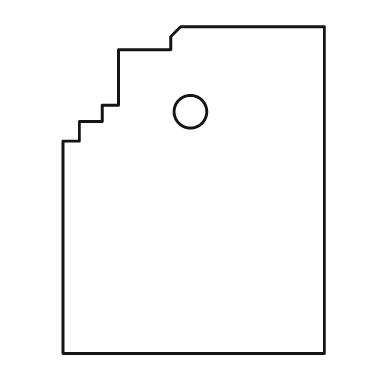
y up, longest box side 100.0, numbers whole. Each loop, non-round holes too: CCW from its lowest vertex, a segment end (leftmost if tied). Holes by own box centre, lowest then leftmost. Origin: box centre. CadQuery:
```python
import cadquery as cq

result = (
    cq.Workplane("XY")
    .moveTo(-40.0, -50.0)
    .lineTo(40.0, -50.0)
    .lineTo(40.0, 50.0)
    .lineTo(-4.0, 50.0)
    .lineTo(-7.0, 47.0)
    .lineTo(-7.0, 43.0)
    .lineTo(-23.0, 43.0)
    .lineTo(-23.0, 26.0)
    .lineTo(-28.0, 26.0)
    .lineTo(-28.0, 21.0)
    .lineTo(-35.0, 21.0)
    .lineTo(-35.0, 15.0)
    .lineTo(-40.0, 15.0)
    .close()
    .moveTo(-1.0, 24.0)
    .circle(5.0)
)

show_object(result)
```